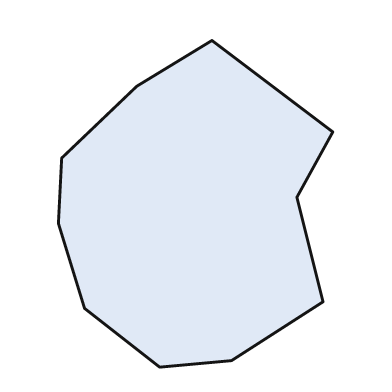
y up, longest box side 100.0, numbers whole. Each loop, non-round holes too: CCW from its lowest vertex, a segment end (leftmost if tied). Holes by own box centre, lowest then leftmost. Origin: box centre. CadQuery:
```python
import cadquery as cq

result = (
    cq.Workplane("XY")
    .moveTo(-11.0, -50.0)
    .lineTo(11.0, -48.0)
    .lineTo(39.0, -30.0)
    .lineTo(31.0, 2.0)
    .lineTo(42.0, 22.0)
    .lineTo(5.0, 50.0)
    .lineTo(-18.0, 36.0)
    .lineTo(-41.0, 14.0)
    .lineTo(-42.0, -6.0)
    .lineTo(-34.0, -32.0)
    .close()
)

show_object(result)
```